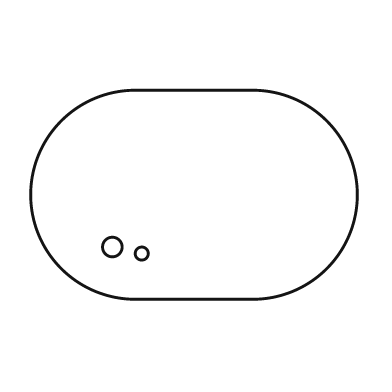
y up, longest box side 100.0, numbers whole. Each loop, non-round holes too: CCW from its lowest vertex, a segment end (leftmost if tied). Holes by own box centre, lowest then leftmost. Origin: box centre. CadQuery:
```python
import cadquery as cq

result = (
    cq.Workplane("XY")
    .moveTo(-18.0, -32.0)
    .lineTo(18.0, -32.0)
    .threePointArc((50.0, 0.0), (18.0, 32.0))
    .lineTo(-18.0, 32.0)
    .threePointArc((-50.0, 0.0), (-18.0, -32.0))
    .close()
    .moveTo(-16.0, -18.0)
    .circle(2.0)
    .moveTo(-25.0, -16.0)
    .circle(3.0)
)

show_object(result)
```